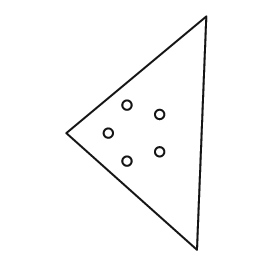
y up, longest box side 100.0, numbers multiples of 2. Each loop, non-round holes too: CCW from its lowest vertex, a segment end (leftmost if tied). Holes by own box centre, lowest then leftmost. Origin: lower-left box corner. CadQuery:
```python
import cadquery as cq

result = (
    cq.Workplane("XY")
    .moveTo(56.0, 0.0)
    .lineTo(60.0, 100.0)
    .lineTo(0.0, 50.0)
    .close()
    .moveTo(26.0, 38.0)
    .circle(2.0)
    .moveTo(40.0, 42.0)
    .circle(2.0)
    .moveTo(18.0, 50.0)
    .circle(2.0)
    .moveTo(40.0, 58.0)
    .circle(2.0)
    .moveTo(26.0, 62.0)
    .circle(2.0)
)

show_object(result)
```